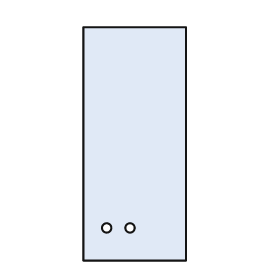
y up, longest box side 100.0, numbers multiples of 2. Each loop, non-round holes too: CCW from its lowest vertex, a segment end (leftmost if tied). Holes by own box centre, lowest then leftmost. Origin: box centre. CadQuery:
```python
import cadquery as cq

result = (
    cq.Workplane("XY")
    .moveTo(-22.0, -50.0)
    .lineTo(22.0, -50.0)
    .lineTo(22.0, 50.0)
    .lineTo(-22.0, 50.0)
    .close()
    .moveTo(-12.0, -36.0)
    .circle(2.0)
    .moveTo(-2.0, -36.0)
    .circle(2.0)
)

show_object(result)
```